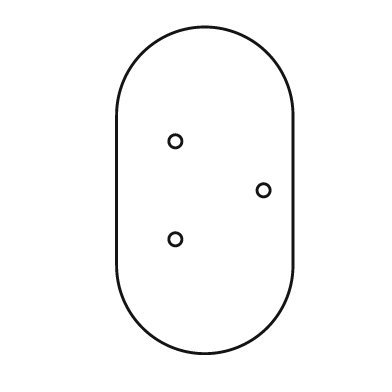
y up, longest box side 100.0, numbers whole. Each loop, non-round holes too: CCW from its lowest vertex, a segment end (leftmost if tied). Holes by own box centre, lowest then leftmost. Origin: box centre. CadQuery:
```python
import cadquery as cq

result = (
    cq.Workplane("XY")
    .moveTo(-27.0, -23.0)
    .threePointArc((0.0, -50.0), (27.0, -23.0))
    .lineTo(27.0, 23.0)
    .threePointArc((0.0, 50.0), (-27.0, 23.0))
    .close()
    .moveTo(-9.0, -15.0)
    .circle(2.0)
    .moveTo(18.0, 0.0)
    .circle(2.0)
    .moveTo(-9.0, 15.0)
    .circle(2.0)
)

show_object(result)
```